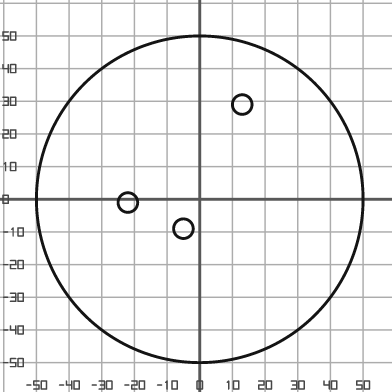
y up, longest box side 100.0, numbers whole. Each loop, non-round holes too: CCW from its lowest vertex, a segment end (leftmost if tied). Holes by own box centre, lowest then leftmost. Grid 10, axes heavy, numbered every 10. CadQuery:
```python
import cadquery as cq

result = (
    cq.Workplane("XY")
    .moveTo(0.0, 0.0)
    .circle(50.0)
    .moveTo(-5.0, -9.0)
    .circle(3.0)
    .moveTo(-22.0, -1.0)
    .circle(3.0)
    .moveTo(13.0, 29.0)
    .circle(3.0)
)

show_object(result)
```